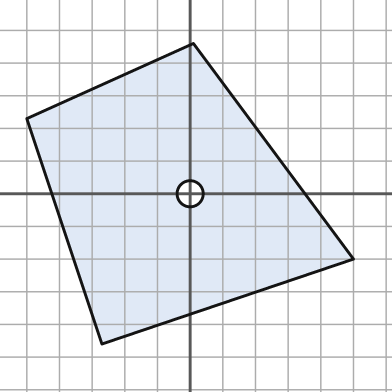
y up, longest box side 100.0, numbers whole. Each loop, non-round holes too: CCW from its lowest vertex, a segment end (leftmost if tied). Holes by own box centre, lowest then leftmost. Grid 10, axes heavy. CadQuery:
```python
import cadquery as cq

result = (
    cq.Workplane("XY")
    .moveTo(-27.0, -46.0)
    .lineTo(50.0, -20.0)
    .lineTo(1.0, 46.0)
    .lineTo(-50.0, 23.0)
    .close()
    .moveTo(0.0, 0.0)
    .circle(4.0)
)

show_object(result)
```